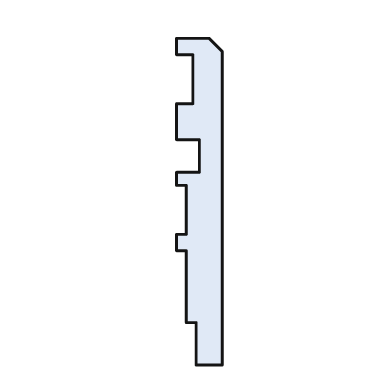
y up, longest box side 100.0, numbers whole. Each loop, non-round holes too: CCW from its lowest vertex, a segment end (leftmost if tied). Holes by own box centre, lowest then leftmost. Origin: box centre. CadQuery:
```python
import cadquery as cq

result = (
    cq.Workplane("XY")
    .moveTo(-1.0, -50.0)
    .lineTo(7.0, -50.0)
    .lineTo(7.0, 46.0)
    .lineTo(3.0, 50.0)
    .lineTo(-7.0, 50.0)
    .lineTo(-7.0, 45.0)
    .lineTo(-2.0, 45.0)
    .lineTo(-2.0, 30.0)
    .lineTo(-7.0, 30.0)
    .lineTo(-7.0, 19.0)
    .lineTo(0.0, 19.0)
    .lineTo(0.0, 9.0)
    .lineTo(-7.0, 9.0)
    .lineTo(-7.0, 5.0)
    .lineTo(-4.0, 5.0)
    .lineTo(-4.0, -10.0)
    .lineTo(-7.0, -10.0)
    .lineTo(-7.0, -15.0)
    .lineTo(-4.0, -15.0)
    .lineTo(-4.0, -37.0)
    .lineTo(-1.0, -37.0)
    .close()
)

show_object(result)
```